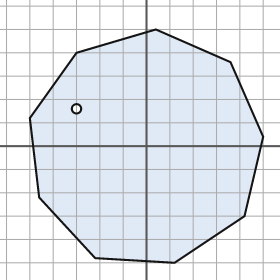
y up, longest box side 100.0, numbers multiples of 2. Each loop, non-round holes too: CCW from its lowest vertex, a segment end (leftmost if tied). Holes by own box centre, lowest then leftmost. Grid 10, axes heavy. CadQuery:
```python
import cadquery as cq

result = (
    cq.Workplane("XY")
    .moveTo(12.0, -50.0)
    .lineTo(42.0, -30.0)
    .lineTo(50.0, 4.0)
    .lineTo(36.0, 36.0)
    .lineTo(4.0, 50.0)
    .lineTo(-30.0, 40.0)
    .lineTo(-50.0, 12.0)
    .lineTo(-46.0, -22.0)
    .lineTo(-22.0, -48.0)
    .close()
    .moveTo(-30.0, 16.0)
    .circle(2.0)
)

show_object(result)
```